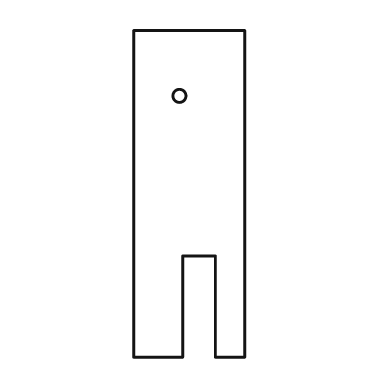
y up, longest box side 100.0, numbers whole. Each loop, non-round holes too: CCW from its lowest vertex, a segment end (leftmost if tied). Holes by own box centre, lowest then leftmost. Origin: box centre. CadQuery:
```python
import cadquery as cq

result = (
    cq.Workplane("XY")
    .moveTo(-17.0, -50.0)
    .lineTo(-2.0, -50.0)
    .lineTo(-2.0, -19.0)
    .lineTo(8.0, -19.0)
    .lineTo(8.0, -50.0)
    .lineTo(17.0, -50.0)
    .lineTo(17.0, 50.0)
    .lineTo(-17.0, 50.0)
    .close()
    .moveTo(-3.0, 30.0)
    .circle(2.0)
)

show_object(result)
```